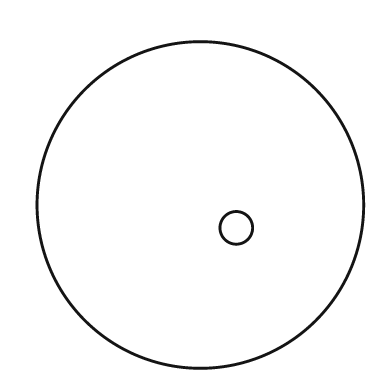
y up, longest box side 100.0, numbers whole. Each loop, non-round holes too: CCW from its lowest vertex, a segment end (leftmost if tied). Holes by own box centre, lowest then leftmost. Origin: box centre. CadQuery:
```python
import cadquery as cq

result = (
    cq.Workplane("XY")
    .moveTo(0.0, 0.0)
    .circle(50.0)
    .moveTo(11.0, -7.0)
    .circle(5.0)
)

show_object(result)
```